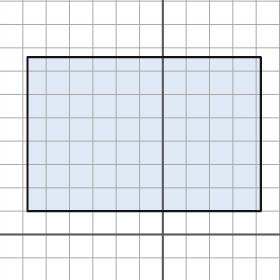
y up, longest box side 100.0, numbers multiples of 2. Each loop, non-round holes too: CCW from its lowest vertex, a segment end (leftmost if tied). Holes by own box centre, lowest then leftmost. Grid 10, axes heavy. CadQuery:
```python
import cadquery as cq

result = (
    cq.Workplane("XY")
    .moveTo(-58.0, 10.0)
    .lineTo(42.0, 10.0)
    .lineTo(42.0, 76.0)
    .lineTo(-58.0, 76.0)
    .close()
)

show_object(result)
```